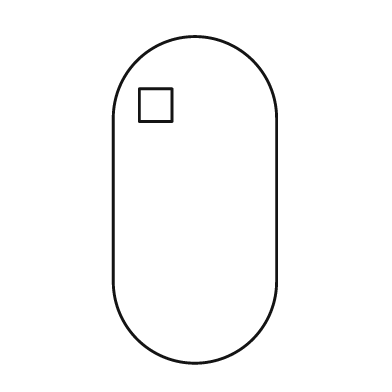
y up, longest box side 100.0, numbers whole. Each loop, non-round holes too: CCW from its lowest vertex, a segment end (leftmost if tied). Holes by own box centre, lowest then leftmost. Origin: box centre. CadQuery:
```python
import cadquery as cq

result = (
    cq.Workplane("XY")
    .moveTo(-25.0, -25.0)
    .threePointArc((0.0, -50.0), (25.0, -25.0))
    .lineTo(25.0, 25.0)
    .threePointArc((0.0, 50.0), (-25.0, 25.0))
    .close()
    .moveTo(-17.0, 24.0)
    .lineTo(-7.0, 24.0)
    .lineTo(-7.0, 34.0)
    .lineTo(-17.0, 34.0)
    .close()
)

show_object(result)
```